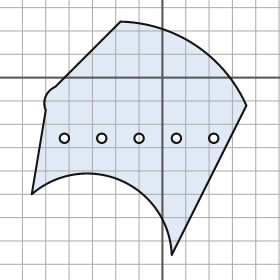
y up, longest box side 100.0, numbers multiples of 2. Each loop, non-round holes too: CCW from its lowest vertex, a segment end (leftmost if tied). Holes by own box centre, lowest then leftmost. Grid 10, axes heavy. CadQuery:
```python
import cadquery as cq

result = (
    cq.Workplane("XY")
    .moveTo(4.0, -76.0)
    .lineTo(36.0, -12.0)
    .threePointArc((14.0, 14.0), (-18.0, 24.0))
    .lineTo(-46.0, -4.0)
    .threePointArc((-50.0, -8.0), (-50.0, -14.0))
    .lineTo(-56.0, -50.0)
    .threePointArc((-18.0, -44.0), (4.0, -76.0))
    .close()
    .moveTo(-42.0, -26.0)
    .circle(2.0)
    .moveTo(-26.0, -26.0)
    .circle(2.0)
    .moveTo(-10.0, -26.0)
    .circle(2.0)
    .moveTo(6.0, -26.0)
    .circle(2.0)
    .moveTo(22.0, -26.0)
    .circle(2.0)
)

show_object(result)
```